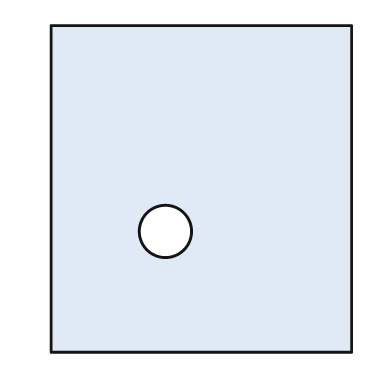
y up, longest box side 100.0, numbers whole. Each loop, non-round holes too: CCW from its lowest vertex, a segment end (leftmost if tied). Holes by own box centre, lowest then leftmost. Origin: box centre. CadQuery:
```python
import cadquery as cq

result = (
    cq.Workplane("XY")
    .moveTo(-46.0, -50.0)
    .lineTo(46.0, -50.0)
    .lineTo(46.0, 50.0)
    .lineTo(-46.0, 50.0)
    .close()
    .moveTo(-11.0, -13.0)
    .circle(8.0)
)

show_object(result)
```